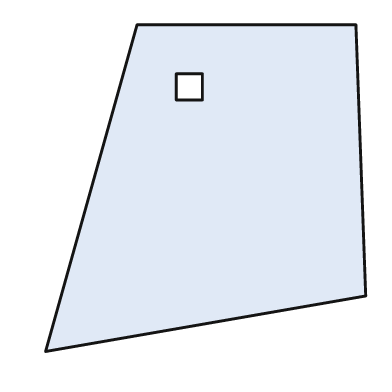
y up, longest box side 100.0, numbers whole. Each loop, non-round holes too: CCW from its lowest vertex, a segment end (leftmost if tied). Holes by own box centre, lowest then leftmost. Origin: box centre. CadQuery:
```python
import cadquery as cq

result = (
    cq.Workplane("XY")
    .moveTo(-49.0, -50.0)
    .lineTo(49.0, -33.0)
    .lineTo(46.0, 50.0)
    .lineTo(-21.0, 50.0)
    .close()
    .moveTo(-9.0, 27.0)
    .lineTo(-1.0, 27.0)
    .lineTo(-1.0, 35.0)
    .lineTo(-9.0, 35.0)
    .close()
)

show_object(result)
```